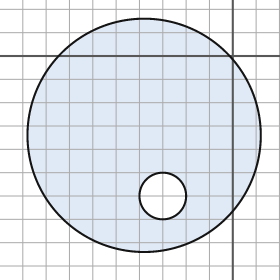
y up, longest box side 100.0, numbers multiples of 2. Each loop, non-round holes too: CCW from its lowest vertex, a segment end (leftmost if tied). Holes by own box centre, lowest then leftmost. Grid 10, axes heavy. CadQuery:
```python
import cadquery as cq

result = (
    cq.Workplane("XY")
    .moveTo(-38.0, -34.0)
    .circle(50.0)
    .moveTo(-30.0, -60.0)
    .circle(10.0)
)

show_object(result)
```